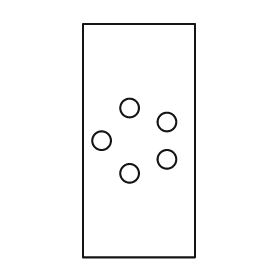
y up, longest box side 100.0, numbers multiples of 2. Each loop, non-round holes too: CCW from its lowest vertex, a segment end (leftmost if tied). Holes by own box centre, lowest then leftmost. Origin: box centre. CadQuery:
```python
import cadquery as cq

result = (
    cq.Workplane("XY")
    .moveTo(-24.0, -50.0)
    .lineTo(24.0, -50.0)
    .lineTo(24.0, 50.0)
    .lineTo(-24.0, 50.0)
    .close()
    .moveTo(-4.0, -14.0)
    .circle(4.0)
    .moveTo(12.0, -8.0)
    .circle(4.0)
    .moveTo(-16.0, 0.0)
    .circle(4.0)
    .moveTo(12.0, 8.0)
    .circle(4.0)
    .moveTo(-4.0, 14.0)
    .circle(4.0)
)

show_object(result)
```